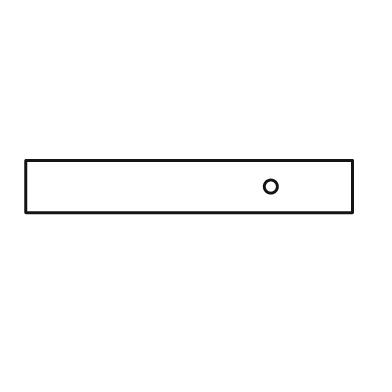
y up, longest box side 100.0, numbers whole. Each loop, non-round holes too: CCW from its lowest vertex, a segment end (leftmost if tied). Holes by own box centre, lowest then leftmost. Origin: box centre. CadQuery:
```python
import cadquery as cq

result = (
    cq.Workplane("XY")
    .moveTo(-50.0, -8.0)
    .lineTo(50.0, -8.0)
    .lineTo(50.0, 8.0)
    .lineTo(-50.0, 8.0)
    .close()
    .moveTo(25.0, 0.0)
    .circle(2.0)
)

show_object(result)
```